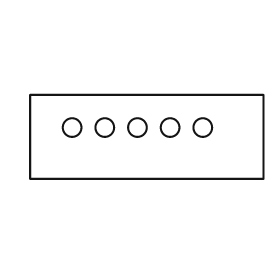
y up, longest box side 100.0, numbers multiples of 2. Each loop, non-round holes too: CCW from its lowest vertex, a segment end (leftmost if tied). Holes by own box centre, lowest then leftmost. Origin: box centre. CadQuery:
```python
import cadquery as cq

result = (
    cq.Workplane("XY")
    .moveTo(-50.0, -18.0)
    .lineTo(50.0, -18.0)
    .lineTo(50.0, 18.0)
    .lineTo(-50.0, 18.0)
    .close()
    .moveTo(-32.0, 4.0)
    .circle(4.0)
    .moveTo(-18.0, 4.0)
    .circle(4.0)
    .moveTo(-4.0, 4.0)
    .circle(4.0)
    .moveTo(10.0, 4.0)
    .circle(4.0)
    .moveTo(24.0, 4.0)
    .circle(4.0)
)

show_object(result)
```